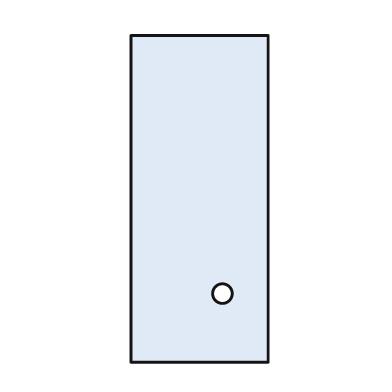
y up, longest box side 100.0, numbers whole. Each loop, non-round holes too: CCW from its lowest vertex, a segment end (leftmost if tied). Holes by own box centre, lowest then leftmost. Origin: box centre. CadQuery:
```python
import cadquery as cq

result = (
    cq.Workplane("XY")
    .moveTo(-21.0, -50.0)
    .lineTo(21.0, -50.0)
    .lineTo(21.0, 50.0)
    .lineTo(-21.0, 50.0)
    .close()
    .moveTo(7.0, -29.0)
    .circle(3.0)
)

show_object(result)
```